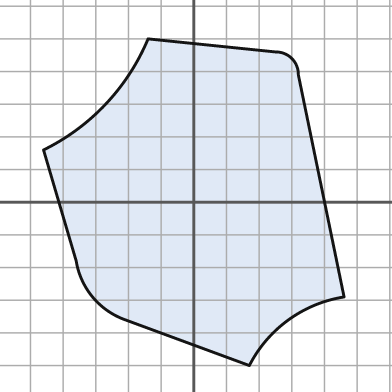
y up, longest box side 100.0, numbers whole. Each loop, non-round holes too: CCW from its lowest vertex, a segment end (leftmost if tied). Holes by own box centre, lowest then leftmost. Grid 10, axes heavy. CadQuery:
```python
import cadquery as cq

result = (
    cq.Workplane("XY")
    .moveTo(17.0, -50.0)
    .threePointArc((29.0, -36.0), (46.0, -29.0))
    .lineTo(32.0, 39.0)
    .threePointArc((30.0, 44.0), (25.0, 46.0))
    .lineTo(-14.0, 50.0)
    .threePointArc((-27.0, 30.0), (-46.0, 16.0))
    .lineTo(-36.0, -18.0)
    .threePointArc((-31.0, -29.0), (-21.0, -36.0))
    .close()
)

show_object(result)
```